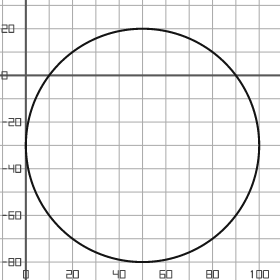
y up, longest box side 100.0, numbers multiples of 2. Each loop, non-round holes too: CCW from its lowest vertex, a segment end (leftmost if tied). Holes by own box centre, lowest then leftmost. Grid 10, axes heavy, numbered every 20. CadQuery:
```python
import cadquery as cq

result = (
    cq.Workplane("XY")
    .moveTo(50.0, -30.0)
    .circle(50.0)
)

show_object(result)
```